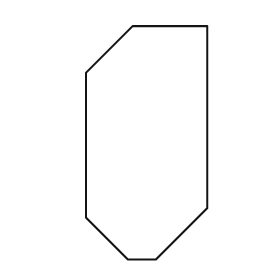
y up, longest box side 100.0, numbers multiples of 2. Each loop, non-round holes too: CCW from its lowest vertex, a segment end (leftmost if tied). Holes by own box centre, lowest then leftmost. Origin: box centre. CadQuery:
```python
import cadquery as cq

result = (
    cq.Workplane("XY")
    .moveTo(-8.0, -50.0)
    .lineTo(4.0, -50.0)
    .lineTo(26.0, -28.0)
    .lineTo(26.0, 50.0)
    .lineTo(-6.0, 50.0)
    .lineTo(-26.0, 30.0)
    .lineTo(-26.0, -32.0)
    .close()
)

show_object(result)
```